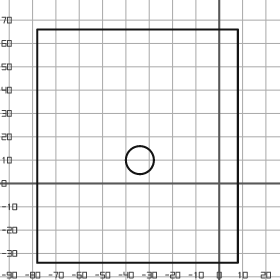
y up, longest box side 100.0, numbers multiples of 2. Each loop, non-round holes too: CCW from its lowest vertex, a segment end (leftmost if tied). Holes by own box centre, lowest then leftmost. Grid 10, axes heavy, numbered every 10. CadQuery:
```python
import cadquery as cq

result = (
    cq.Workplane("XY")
    .moveTo(-78.0, -34.0)
    .lineTo(8.0, -34.0)
    .lineTo(8.0, 66.0)
    .lineTo(-78.0, 66.0)
    .close()
    .moveTo(-34.0, 10.0)
    .circle(6.0)
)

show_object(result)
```